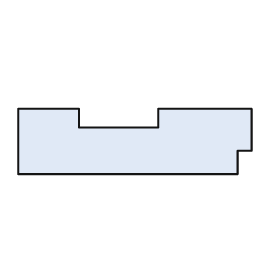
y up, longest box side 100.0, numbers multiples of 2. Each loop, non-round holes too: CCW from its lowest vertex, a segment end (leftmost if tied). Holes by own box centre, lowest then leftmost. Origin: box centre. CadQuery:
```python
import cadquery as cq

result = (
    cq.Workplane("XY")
    .moveTo(-50.0, -14.0)
    .lineTo(44.0, -14.0)
    .lineTo(44.0, -4.0)
    .lineTo(50.0, -4.0)
    .lineTo(50.0, 14.0)
    .lineTo(10.0, 14.0)
    .lineTo(10.0, 6.0)
    .lineTo(-24.0, 6.0)
    .lineTo(-24.0, 14.0)
    .lineTo(-50.0, 14.0)
    .close()
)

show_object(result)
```